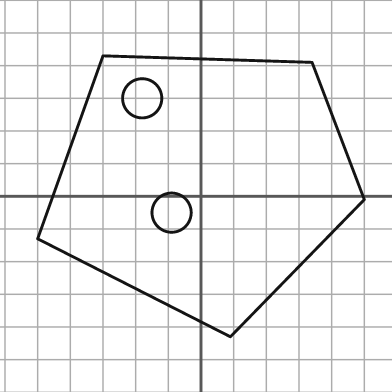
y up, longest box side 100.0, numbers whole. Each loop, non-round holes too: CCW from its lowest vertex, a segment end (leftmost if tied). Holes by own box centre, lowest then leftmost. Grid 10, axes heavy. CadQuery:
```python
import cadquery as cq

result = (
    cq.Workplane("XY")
    .moveTo(9.0, -43.0)
    .lineTo(50.0, -1.0)
    .lineTo(34.0, 41.0)
    .lineTo(-30.0, 43.0)
    .lineTo(-50.0, -13.0)
    .close()
    .moveTo(-9.0, -5.0)
    .circle(6.0)
    .moveTo(-18.0, 30.0)
    .circle(6.0)
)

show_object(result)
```